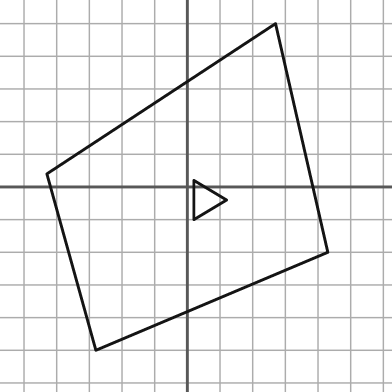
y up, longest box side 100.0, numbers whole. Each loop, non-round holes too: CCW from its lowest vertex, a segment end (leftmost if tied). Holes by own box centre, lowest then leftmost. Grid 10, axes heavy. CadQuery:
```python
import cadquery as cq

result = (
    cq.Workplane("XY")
    .moveTo(-28.0, -50.0)
    .lineTo(43.0, -20.0)
    .lineTo(27.0, 50.0)
    .lineTo(-43.0, 4.0)
    .close()
    .moveTo(2.0, -10.0)
    .lineTo(12.0, -4.0)
    .lineTo(2.0, 2.0)
    .close()
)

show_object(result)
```